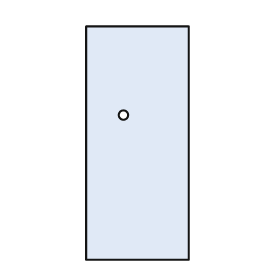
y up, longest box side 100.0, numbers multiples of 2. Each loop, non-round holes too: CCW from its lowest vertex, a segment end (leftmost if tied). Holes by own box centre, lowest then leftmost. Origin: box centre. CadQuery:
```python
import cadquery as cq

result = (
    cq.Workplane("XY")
    .moveTo(-22.0, -50.0)
    .lineTo(22.0, -50.0)
    .lineTo(22.0, 50.0)
    .lineTo(-22.0, 50.0)
    .close()
    .moveTo(-6.0, 12.0)
    .circle(2.0)
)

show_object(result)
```